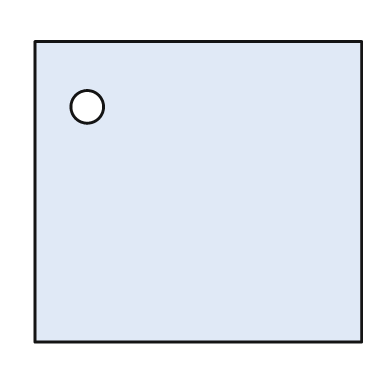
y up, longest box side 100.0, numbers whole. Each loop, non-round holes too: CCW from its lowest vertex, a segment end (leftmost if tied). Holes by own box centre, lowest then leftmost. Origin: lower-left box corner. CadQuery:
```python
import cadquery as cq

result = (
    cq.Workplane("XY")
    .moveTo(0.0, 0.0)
    .lineTo(100.0, 0.0)
    .lineTo(100.0, 92.0)
    .lineTo(0.0, 92.0)
    .close()
    .moveTo(16.0, 72.0)
    .circle(5.0)
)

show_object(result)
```